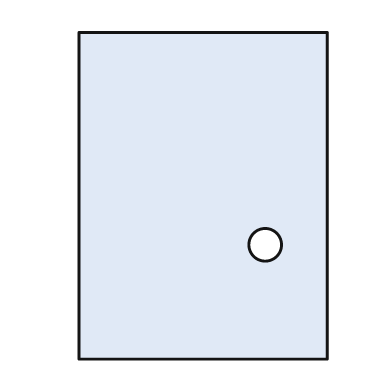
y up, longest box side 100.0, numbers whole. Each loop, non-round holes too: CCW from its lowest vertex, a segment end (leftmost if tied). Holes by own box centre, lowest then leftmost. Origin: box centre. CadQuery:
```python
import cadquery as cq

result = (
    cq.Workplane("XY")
    .moveTo(-38.0, -50.0)
    .lineTo(38.0, -50.0)
    .lineTo(38.0, 50.0)
    .lineTo(-38.0, 50.0)
    .close()
    .moveTo(19.0, -15.0)
    .circle(5.0)
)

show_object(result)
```